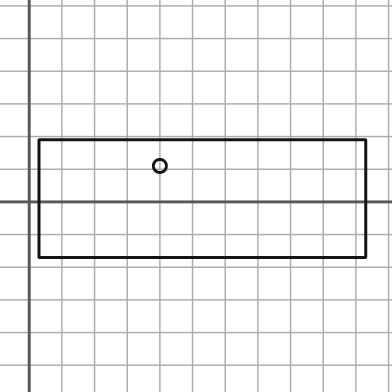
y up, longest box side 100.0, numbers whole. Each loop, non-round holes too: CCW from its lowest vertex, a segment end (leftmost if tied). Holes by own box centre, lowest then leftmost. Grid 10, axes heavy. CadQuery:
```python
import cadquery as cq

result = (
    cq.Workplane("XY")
    .moveTo(3.0, -17.0)
    .lineTo(103.0, -17.0)
    .lineTo(103.0, 19.0)
    .lineTo(3.0, 19.0)
    .close()
    .moveTo(40.0, 11.0)
    .circle(2.0)
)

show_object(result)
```